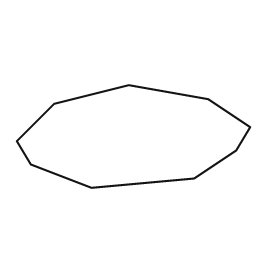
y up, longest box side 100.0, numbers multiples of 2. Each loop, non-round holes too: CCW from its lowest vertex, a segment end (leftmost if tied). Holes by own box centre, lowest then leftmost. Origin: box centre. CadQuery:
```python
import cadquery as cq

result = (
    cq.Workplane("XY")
    .moveTo(-18.0, -22.0)
    .lineTo(26.0, -18.0)
    .lineTo(44.0, -6.0)
    .lineTo(50.0, 4.0)
    .lineTo(32.0, 16.0)
    .lineTo(-2.0, 22.0)
    .lineTo(-34.0, 14.0)
    .lineTo(-50.0, -2.0)
    .lineTo(-44.0, -12.0)
    .close()
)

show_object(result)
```